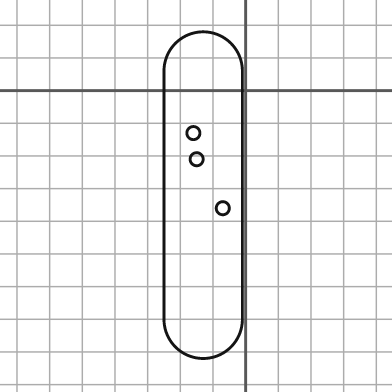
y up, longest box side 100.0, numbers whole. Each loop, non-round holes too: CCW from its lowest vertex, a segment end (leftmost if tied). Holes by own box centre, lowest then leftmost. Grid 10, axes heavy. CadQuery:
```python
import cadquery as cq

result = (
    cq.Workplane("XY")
    .moveTo(-25.0, -70.0)
    .threePointArc((-13.0, -82.0), (-1.0, -70.0))
    .lineTo(-1.0, 6.0)
    .threePointArc((-13.0, 18.0), (-25.0, 6.0))
    .close()
    .moveTo(-7.0, -36.0)
    .circle(2.0)
    .moveTo(-15.0, -21.0)
    .circle(2.0)
    .moveTo(-16.0, -13.0)
    .circle(2.0)
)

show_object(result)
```